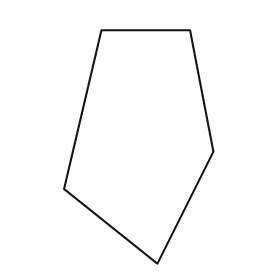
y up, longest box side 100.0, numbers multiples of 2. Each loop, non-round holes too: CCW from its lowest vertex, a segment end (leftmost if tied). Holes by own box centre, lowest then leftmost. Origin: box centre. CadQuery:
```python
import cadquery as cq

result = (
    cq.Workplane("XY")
    .moveTo(8.0, -50.0)
    .lineTo(32.0, -2.0)
    .lineTo(22.0, 50.0)
    .lineTo(-16.0, 50.0)
    .lineTo(-32.0, -18.0)
    .close()
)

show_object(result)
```